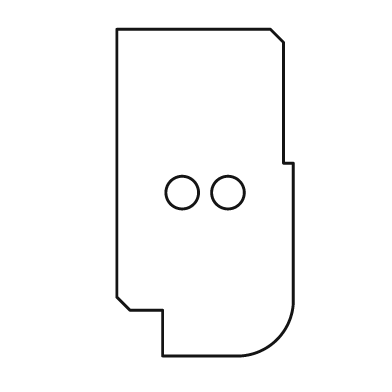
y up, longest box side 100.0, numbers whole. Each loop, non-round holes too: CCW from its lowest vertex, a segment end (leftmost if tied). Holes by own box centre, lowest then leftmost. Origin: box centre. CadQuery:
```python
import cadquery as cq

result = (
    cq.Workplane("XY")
    .moveTo(-13.0, -50.0)
    .lineTo(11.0, -50.0)
    .threePointArc((22.0, -45.0), (27.0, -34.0))
    .lineTo(27.0, 9.0)
    .lineTo(24.0, 9.0)
    .lineTo(24.0, 46.0)
    .lineTo(20.0, 50.0)
    .lineTo(-27.0, 50.0)
    .lineTo(-27.0, -32.0)
    .lineTo(-23.0, -36.0)
    .lineTo(-13.0, -36.0)
    .close()
    .moveTo(-7.0, 0.0)
    .circle(5.0)
    .moveTo(7.0, 0.0)
    .circle(5.0)
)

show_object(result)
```